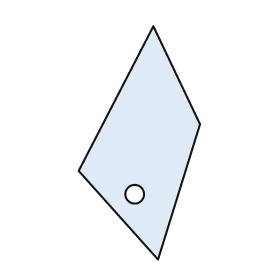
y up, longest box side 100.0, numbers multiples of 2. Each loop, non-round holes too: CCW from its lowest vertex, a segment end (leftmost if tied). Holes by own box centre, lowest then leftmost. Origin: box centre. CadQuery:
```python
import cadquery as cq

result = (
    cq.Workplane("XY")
    .moveTo(8.0, -50.0)
    .lineTo(26.0, 8.0)
    .lineTo(6.0, 50.0)
    .lineTo(-26.0, -12.0)
    .close()
    .moveTo(-2.0, -22.0)
    .circle(4.0)
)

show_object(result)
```